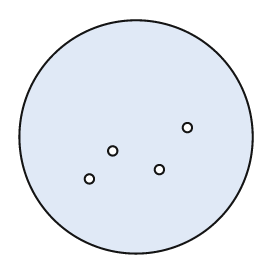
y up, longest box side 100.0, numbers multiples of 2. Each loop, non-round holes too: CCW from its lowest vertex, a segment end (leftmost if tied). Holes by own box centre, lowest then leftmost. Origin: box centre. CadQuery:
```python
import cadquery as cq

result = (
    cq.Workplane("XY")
    .moveTo(0.0, 0.0)
    .circle(50.0)
    .moveTo(-20.0, -18.0)
    .circle(2.0)
    .moveTo(10.0, -14.0)
    .circle(2.0)
    .moveTo(-10.0, -6.0)
    .circle(2.0)
    .moveTo(22.0, 4.0)
    .circle(2.0)
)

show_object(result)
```